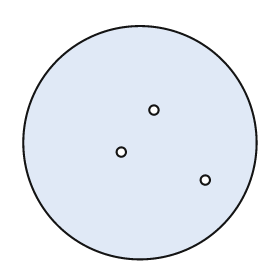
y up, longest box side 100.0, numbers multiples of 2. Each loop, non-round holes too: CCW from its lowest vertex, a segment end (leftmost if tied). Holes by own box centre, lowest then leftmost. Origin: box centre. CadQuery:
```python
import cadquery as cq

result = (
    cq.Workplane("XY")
    .moveTo(0.0, 0.0)
    .circle(50.0)
    .moveTo(28.0, -16.0)
    .circle(2.0)
    .moveTo(-8.0, -4.0)
    .circle(2.0)
    .moveTo(6.0, 14.0)
    .circle(2.0)
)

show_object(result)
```